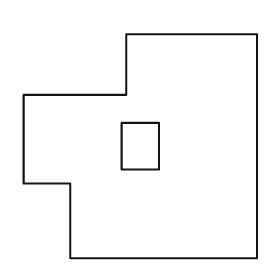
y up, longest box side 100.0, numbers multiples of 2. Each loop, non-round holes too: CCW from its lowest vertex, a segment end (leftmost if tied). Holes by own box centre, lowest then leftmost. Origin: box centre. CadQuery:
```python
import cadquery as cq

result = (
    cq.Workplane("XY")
    .moveTo(-30.0, -48.0)
    .lineTo(50.0, -48.0)
    .lineTo(50.0, 48.0)
    .lineTo(-6.0, 48.0)
    .lineTo(-6.0, 22.0)
    .lineTo(-50.0, 22.0)
    .lineTo(-50.0, -16.0)
    .lineTo(-30.0, -16.0)
    .close()
    .moveTo(-8.0, -10.0)
    .lineTo(8.0, -10.0)
    .lineTo(8.0, 10.0)
    .lineTo(-8.0, 10.0)
    .close()
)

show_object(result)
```